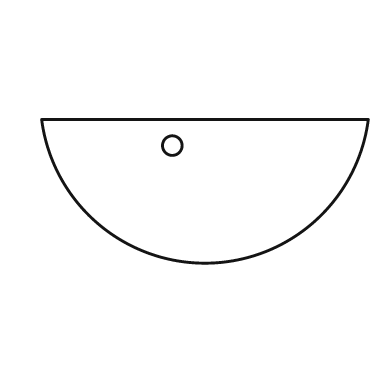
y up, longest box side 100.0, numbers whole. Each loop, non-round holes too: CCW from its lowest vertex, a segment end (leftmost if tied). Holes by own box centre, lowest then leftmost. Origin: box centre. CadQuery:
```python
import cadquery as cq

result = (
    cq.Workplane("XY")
    .moveTo(-50.0, 22.0)
    .threePointArc((0.0, -22.0), (50.0, 22.0))
    .close()
    .moveTo(-10.0, 14.0)
    .circle(3.0)
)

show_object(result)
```